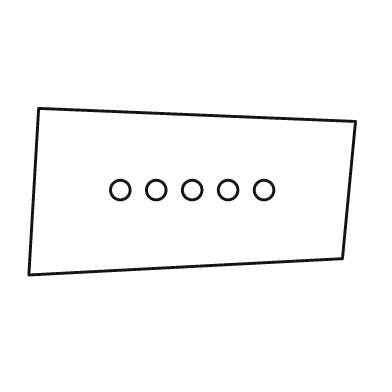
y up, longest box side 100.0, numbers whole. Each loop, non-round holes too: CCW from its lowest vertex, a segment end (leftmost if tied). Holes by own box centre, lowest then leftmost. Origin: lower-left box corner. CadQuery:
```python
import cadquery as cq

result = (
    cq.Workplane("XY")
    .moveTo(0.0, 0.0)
    .lineTo(96.0, 5.0)
    .lineTo(100.0, 47.0)
    .lineTo(3.0, 51.0)
    .close()
    .moveTo(28.0, 26.0)
    .circle(3.0)
    .moveTo(39.0, 26.0)
    .circle(3.0)
    .moveTo(50.0, 26.0)
    .circle(3.0)
    .moveTo(61.0, 26.0)
    .circle(3.0)
    .moveTo(72.0, 26.0)
    .circle(3.0)
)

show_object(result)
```